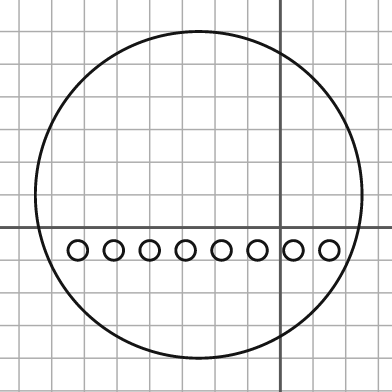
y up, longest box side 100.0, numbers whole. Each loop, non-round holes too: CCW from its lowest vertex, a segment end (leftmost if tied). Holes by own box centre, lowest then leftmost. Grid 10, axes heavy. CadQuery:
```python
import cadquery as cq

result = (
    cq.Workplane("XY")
    .moveTo(-25.0, 10.0)
    .circle(50.0)
    .moveTo(-62.0, -7.0)
    .circle(3.0)
    .moveTo(-51.0, -7.0)
    .circle(3.0)
    .moveTo(-40.0, -7.0)
    .circle(3.0)
    .moveTo(-29.0, -7.0)
    .circle(3.0)
    .moveTo(-18.0, -7.0)
    .circle(3.0)
    .moveTo(-7.0, -7.0)
    .circle(3.0)
    .moveTo(4.0, -7.0)
    .circle(3.0)
    .moveTo(15.0, -7.0)
    .circle(3.0)
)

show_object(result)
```